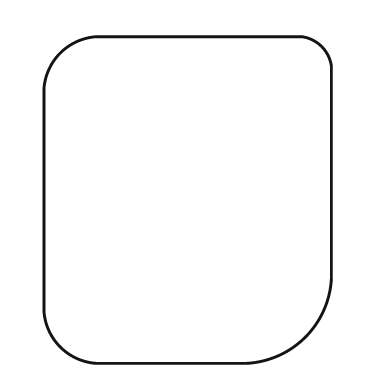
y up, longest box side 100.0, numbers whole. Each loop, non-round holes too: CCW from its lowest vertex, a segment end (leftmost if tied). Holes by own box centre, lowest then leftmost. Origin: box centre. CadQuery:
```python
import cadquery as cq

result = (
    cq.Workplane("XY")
    .moveTo(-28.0, -50.0)
    .lineTo(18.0, -50.0)
    .threePointArc((36.0, -42.0), (44.0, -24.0))
    .lineTo(44.0, 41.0)
    .threePointArc((41.0, 47.0), (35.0, 50.0))
    .lineTo(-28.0, 50.0)
    .threePointArc((-39.0, 45.0), (-44.0, 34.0))
    .lineTo(-44.0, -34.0)
    .threePointArc((-39.0, -45.0), (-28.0, -50.0))
    .close()
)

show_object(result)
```